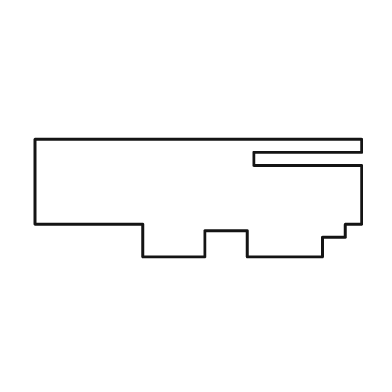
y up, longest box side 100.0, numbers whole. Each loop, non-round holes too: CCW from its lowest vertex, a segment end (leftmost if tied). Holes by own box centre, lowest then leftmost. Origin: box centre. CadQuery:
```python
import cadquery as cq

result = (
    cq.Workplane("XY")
    .moveTo(-17.0, -18.0)
    .lineTo(2.0, -18.0)
    .lineTo(2.0, -10.0)
    .lineTo(15.0, -10.0)
    .lineTo(15.0, -18.0)
    .lineTo(38.0, -18.0)
    .lineTo(38.0, -12.0)
    .lineTo(45.0, -12.0)
    .lineTo(45.0, -8.0)
    .lineTo(50.0, -8.0)
    .lineTo(50.0, 10.0)
    .lineTo(17.0, 10.0)
    .lineTo(17.0, 14.0)
    .lineTo(50.0, 14.0)
    .lineTo(50.0, 18.0)
    .lineTo(-50.0, 18.0)
    .lineTo(-50.0, -8.0)
    .lineTo(-17.0, -8.0)
    .close()
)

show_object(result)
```